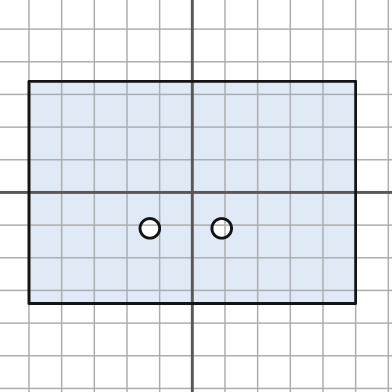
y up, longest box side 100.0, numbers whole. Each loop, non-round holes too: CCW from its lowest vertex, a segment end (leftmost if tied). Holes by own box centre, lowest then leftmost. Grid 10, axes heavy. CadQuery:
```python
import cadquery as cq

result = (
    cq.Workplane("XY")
    .moveTo(-50.0, -34.0)
    .lineTo(50.0, -34.0)
    .lineTo(50.0, 34.0)
    .lineTo(-50.0, 34.0)
    .close()
    .moveTo(-13.0, -11.0)
    .circle(3.0)
    .moveTo(9.0, -11.0)
    .circle(3.0)
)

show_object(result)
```